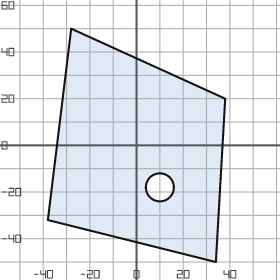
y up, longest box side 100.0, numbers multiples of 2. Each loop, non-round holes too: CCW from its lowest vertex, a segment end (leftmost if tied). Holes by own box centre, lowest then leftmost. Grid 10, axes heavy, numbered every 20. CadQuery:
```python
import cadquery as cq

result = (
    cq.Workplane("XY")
    .moveTo(34.0, -50.0)
    .lineTo(38.0, 20.0)
    .lineTo(-28.0, 50.0)
    .lineTo(-38.0, -32.0)
    .close()
    .moveTo(10.0, -18.0)
    .circle(6.0)
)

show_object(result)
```